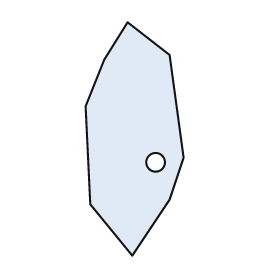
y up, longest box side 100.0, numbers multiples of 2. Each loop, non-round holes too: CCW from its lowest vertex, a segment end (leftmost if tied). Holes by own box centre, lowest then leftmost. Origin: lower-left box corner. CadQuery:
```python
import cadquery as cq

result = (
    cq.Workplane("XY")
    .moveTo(20.0, 0.0)
    .lineTo(36.0, 24.0)
    .lineTo(42.0, 42.0)
    .lineTo(36.0, 86.0)
    .lineTo(18.0, 100.0)
    .lineTo(8.0, 84.0)
    .lineTo(0.0, 64.0)
    .lineTo(2.0, 22.0)
    .close()
    .moveTo(30.0, 40.0)
    .circle(4.0)
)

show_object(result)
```